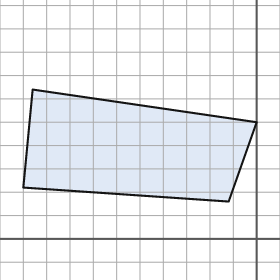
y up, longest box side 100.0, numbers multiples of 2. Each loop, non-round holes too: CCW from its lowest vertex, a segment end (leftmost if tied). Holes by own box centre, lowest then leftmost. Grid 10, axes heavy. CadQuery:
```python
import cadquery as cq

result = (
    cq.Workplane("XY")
    .moveTo(-12.0, 16.0)
    .lineTo(0.0, 50.0)
    .lineTo(-96.0, 64.0)
    .lineTo(-100.0, 22.0)
    .close()
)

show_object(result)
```